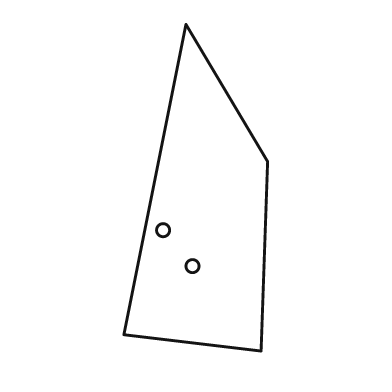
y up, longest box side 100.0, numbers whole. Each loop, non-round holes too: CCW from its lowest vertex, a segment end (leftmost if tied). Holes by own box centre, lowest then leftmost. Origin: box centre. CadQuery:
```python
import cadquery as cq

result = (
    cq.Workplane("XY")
    .moveTo(20.0, -50.0)
    .lineTo(22.0, 8.0)
    .lineTo(-3.0, 50.0)
    .lineTo(-22.0, -45.0)
    .close()
    .moveTo(-1.0, -24.0)
    .circle(2.0)
    .moveTo(-10.0, -13.0)
    .circle(2.0)
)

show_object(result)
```